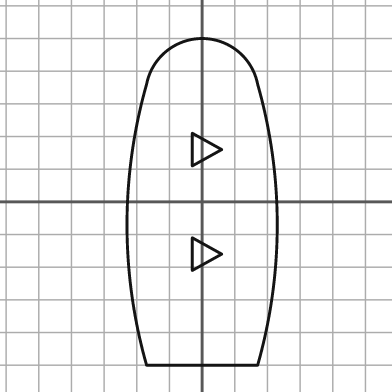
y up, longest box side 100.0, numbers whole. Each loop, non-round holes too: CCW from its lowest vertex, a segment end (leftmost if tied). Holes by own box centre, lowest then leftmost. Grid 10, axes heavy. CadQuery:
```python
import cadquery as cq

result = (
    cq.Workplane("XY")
    .moveTo(-17.0, -50.0)
    .lineTo(17.0, -50.0)
    .threePointArc((23.0, -7.0), (17.0, 36.0))
    .threePointArc((0.0, 50.0), (-17.0, 36.0))
    .threePointArc((-23.0, -7.0), (-17.0, -50.0))
    .close()
    .moveTo(-3.0, -21.0)
    .lineTo(6.0, -16.0)
    .lineTo(-3.0, -11.0)
    .close()
    .moveTo(-3.0, 11.0)
    .lineTo(6.0, 16.0)
    .lineTo(-3.0, 21.0)
    .close()
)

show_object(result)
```